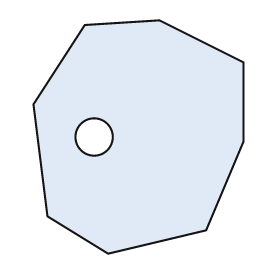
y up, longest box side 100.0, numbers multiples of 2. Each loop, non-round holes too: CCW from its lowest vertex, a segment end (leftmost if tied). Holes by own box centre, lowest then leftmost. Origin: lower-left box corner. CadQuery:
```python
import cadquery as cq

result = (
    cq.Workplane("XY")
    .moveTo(32.0, 0.0)
    .lineTo(74.0, 10.0)
    .lineTo(90.0, 48.0)
    .lineTo(90.0, 82.0)
    .lineTo(54.0, 100.0)
    .lineTo(22.0, 98.0)
    .lineTo(0.0, 64.0)
    .lineTo(6.0, 16.0)
    .close()
    .moveTo(26.0, 50.0)
    .circle(8.0)
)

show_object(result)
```